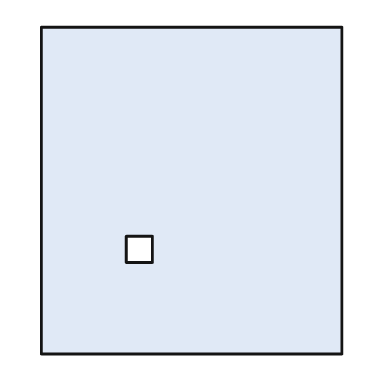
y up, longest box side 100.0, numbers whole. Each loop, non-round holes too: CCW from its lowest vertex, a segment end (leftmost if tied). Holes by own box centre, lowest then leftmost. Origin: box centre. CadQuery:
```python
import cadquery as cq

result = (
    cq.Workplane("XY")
    .moveTo(-46.0, -50.0)
    .lineTo(46.0, -50.0)
    .lineTo(46.0, 50.0)
    .lineTo(-46.0, 50.0)
    .close()
    .moveTo(-20.0, -22.0)
    .lineTo(-12.0, -22.0)
    .lineTo(-12.0, -14.0)
    .lineTo(-20.0, -14.0)
    .close()
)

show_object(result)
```